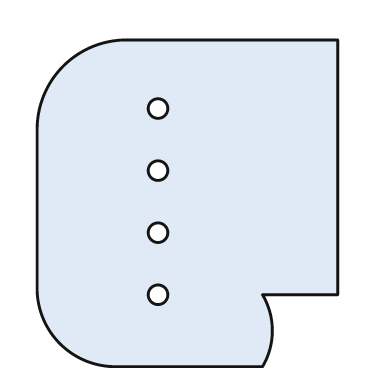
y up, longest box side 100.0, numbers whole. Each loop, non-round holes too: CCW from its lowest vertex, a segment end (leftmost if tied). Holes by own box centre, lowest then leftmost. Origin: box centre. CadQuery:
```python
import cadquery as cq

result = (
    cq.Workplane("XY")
    .moveTo(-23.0, -50.0)
    .lineTo(23.0, -50.0)
    .threePointArc((26.0, -39.0), (23.0, -28.0))
    .lineTo(46.0, -28.0)
    .lineTo(46.0, 50.0)
    .lineTo(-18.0, 50.0)
    .threePointArc((-38.0, 42.0), (-46.0, 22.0))
    .lineTo(-46.0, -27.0)
    .threePointArc((-39.0, -43.0), (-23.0, -50.0))
    .close()
    .moveTo(-9.0, -28.0)
    .circle(3.0)
    .moveTo(-9.0, -9.0)
    .circle(3.0)
    .moveTo(-9.0, 10.0)
    .circle(3.0)
    .moveTo(-9.0, 29.0)
    .circle(3.0)
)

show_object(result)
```